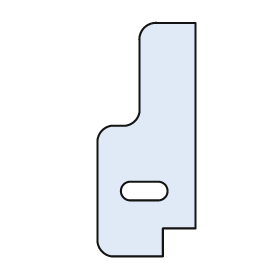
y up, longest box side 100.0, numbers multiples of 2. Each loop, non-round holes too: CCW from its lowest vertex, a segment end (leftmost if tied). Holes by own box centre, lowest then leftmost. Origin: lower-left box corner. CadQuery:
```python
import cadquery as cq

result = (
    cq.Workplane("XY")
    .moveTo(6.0, 0.0)
    .lineTo(28.0, 0.0)
    .lineTo(28.0, 12.0)
    .lineTo(42.0, 12.0)
    .lineTo(42.0, 100.0)
    .lineTo(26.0, 100.0)
    .threePointArc((20.0, 98.0), (18.0, 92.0))
    .lineTo(18.0, 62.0)
    .threePointArc((16.0, 58.0), (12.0, 56.0))
    .lineTo(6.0, 56.0)
    .threePointArc((2.0, 54.0), (0.0, 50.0))
    .lineTo(0.0, 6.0)
    .threePointArc((2.0, 2.0), (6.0, 0.0))
    .close()
    .moveTo(14.0, 24.0)
    .lineTo(26.0, 24.0)
    .threePointArc((30.0, 28.0), (26.0, 32.0))
    .lineTo(14.0, 32.0)
    .threePointArc((10.0, 28.0), (14.0, 24.0))
    .close()
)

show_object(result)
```